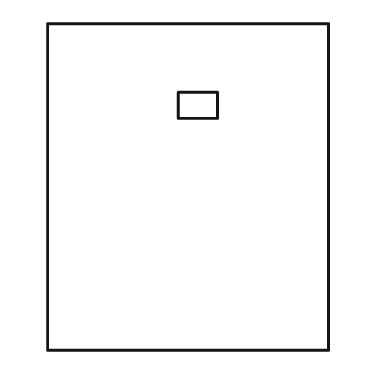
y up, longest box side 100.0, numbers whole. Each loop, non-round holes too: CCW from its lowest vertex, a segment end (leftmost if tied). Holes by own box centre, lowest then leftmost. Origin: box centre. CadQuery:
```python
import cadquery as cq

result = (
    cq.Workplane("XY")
    .moveTo(-43.0, -50.0)
    .lineTo(43.0, -50.0)
    .lineTo(43.0, 50.0)
    .lineTo(-43.0, 50.0)
    .close()
    .moveTo(-3.0, 21.0)
    .lineTo(9.0, 21.0)
    .lineTo(9.0, 29.0)
    .lineTo(-3.0, 29.0)
    .close()
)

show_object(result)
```